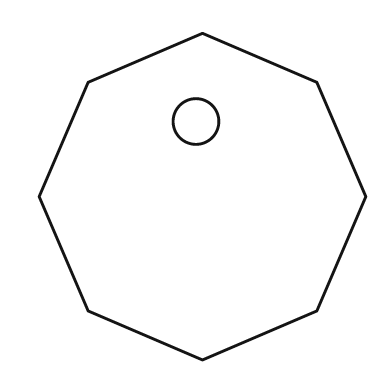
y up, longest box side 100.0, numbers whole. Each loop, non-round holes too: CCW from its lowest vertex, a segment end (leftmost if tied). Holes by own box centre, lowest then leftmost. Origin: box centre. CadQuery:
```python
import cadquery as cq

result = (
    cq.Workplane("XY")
    .moveTo(0.0, -50.0)
    .lineTo(35.0, -35.0)
    .lineTo(50.0, 0.0)
    .lineTo(35.0, 35.0)
    .lineTo(0.0, 50.0)
    .lineTo(-35.0, 35.0)
    .lineTo(-50.0, 0.0)
    .lineTo(-35.0, -35.0)
    .close()
    .moveTo(-2.0, 23.0)
    .circle(7.0)
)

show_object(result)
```